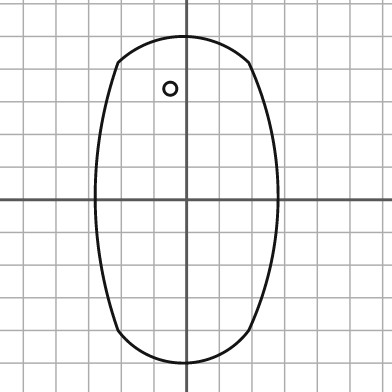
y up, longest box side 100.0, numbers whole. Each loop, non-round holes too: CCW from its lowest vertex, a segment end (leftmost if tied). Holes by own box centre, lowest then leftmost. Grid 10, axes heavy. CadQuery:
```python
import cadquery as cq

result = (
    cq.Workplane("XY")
    .moveTo(-21.0, -40.0)
    .threePointArc((-1.0, -50.0), (19.0, -40.0))
    .threePointArc((28.0, 1.0), (19.0, 42.0))
    .threePointArc((-1.0, 50.0), (-21.0, 42.0))
    .threePointArc((-28.0, 1.0), (-21.0, -40.0))
    .close()
    .moveTo(-5.0, 34.0)
    .circle(2.0)
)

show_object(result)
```